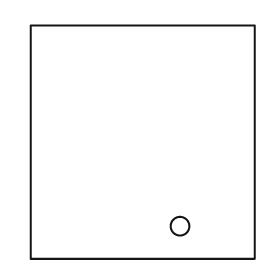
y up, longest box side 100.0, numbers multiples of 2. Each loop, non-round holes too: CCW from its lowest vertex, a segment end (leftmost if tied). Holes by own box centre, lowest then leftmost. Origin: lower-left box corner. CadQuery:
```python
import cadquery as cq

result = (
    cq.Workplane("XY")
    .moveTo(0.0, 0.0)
    .lineTo(96.0, 0.0)
    .lineTo(96.0, 100.0)
    .lineTo(0.0, 100.0)
    .close()
    .moveTo(64.0, 14.0)
    .circle(4.0)
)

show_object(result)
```